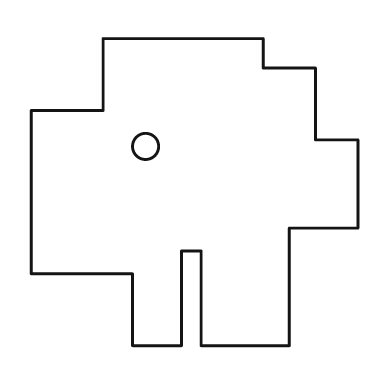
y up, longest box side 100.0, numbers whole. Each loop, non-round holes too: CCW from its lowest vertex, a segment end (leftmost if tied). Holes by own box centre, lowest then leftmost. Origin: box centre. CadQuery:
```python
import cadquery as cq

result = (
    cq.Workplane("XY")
    .moveTo(-19.0, -47.0)
    .lineTo(-4.0, -47.0)
    .lineTo(-4.0, -18.0)
    .lineTo(2.0, -18.0)
    .lineTo(2.0, -47.0)
    .lineTo(29.0, -47.0)
    .lineTo(29.0, -11.0)
    .lineTo(50.0, -11.0)
    .lineTo(50.0, 16.0)
    .lineTo(37.0, 16.0)
    .lineTo(37.0, 38.0)
    .lineTo(21.0, 38.0)
    .lineTo(21.0, 47.0)
    .lineTo(-28.0, 47.0)
    .lineTo(-28.0, 25.0)
    .lineTo(-50.0, 25.0)
    .lineTo(-50.0, -25.0)
    .lineTo(-19.0, -25.0)
    .close()
    .moveTo(-15.0, 14.0)
    .circle(4.0)
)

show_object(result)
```